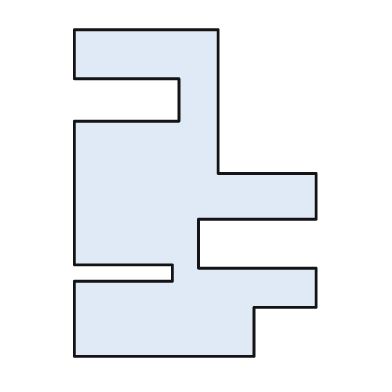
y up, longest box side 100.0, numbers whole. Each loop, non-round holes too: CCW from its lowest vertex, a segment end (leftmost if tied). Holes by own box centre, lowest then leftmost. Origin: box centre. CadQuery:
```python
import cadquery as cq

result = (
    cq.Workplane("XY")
    .moveTo(-37.0, -50.0)
    .lineTo(18.0, -50.0)
    .lineTo(18.0, -35.0)
    .lineTo(37.0, -35.0)
    .lineTo(37.0, -23.0)
    .lineTo(1.0, -23.0)
    .lineTo(1.0, -8.0)
    .lineTo(37.0, -8.0)
    .lineTo(37.0, 6.0)
    .lineTo(7.0, 6.0)
    .lineTo(7.0, 50.0)
    .lineTo(-37.0, 50.0)
    .lineTo(-37.0, 35.0)
    .lineTo(-5.0, 35.0)
    .lineTo(-5.0, 22.0)
    .lineTo(-37.0, 22.0)
    .lineTo(-37.0, -22.0)
    .lineTo(-7.0, -22.0)
    .lineTo(-7.0, -27.0)
    .lineTo(-37.0, -27.0)
    .close()
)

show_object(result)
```